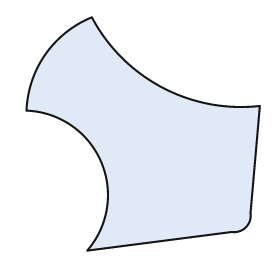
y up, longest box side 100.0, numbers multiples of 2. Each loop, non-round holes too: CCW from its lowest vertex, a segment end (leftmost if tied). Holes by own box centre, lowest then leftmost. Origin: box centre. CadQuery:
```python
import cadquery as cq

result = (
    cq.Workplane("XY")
    .moveTo(-24.0, -50.0)
    .lineTo(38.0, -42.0)
    .threePointArc((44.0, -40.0), (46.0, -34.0))
    .lineTo(50.0, 12.0)
    .threePointArc((8.0, 20.0), (-22.0, 50.0))
    .threePointArc((-42.0, 34.0), (-50.0, 10.0))
    .threePointArc((-18.0, -12.0), (-24.0, -50.0))
    .close()
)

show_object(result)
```